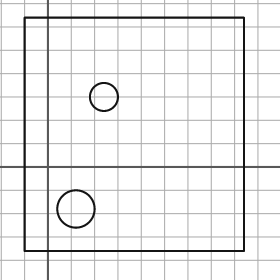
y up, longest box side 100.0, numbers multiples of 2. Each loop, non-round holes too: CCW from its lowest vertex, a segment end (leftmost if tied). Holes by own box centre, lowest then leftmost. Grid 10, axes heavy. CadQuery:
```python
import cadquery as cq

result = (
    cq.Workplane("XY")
    .moveTo(-10.0, -36.0)
    .lineTo(84.0, -36.0)
    .lineTo(84.0, 64.0)
    .lineTo(-10.0, 64.0)
    .close()
    .moveTo(12.0, -18.0)
    .circle(8.0)
    .moveTo(24.0, 30.0)
    .circle(6.0)
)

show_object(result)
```